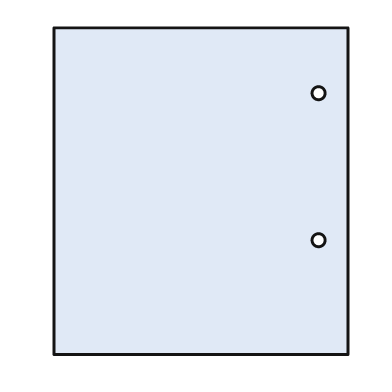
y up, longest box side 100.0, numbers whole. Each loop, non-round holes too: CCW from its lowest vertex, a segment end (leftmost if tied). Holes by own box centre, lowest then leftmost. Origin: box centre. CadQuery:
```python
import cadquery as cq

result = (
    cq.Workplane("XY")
    .moveTo(-45.0, -50.0)
    .lineTo(45.0, -50.0)
    .lineTo(45.0, 50.0)
    .lineTo(-45.0, 50.0)
    .close()
    .moveTo(36.0, -15.0)
    .circle(2.0)
    .moveTo(36.0, 30.0)
    .circle(2.0)
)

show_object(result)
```